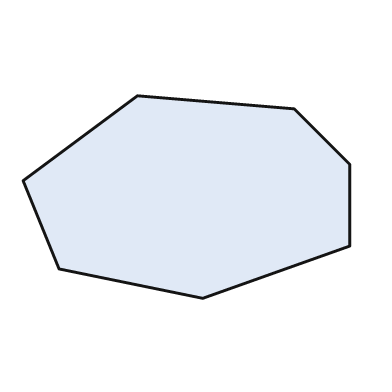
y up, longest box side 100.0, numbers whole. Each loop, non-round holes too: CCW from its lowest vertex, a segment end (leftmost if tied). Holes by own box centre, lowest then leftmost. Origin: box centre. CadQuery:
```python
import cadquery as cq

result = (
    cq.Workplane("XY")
    .moveTo(5.0, -31.0)
    .lineTo(50.0, -15.0)
    .lineTo(50.0, 10.0)
    .lineTo(33.0, 27.0)
    .lineTo(-15.0, 31.0)
    .lineTo(-50.0, 5.0)
    .lineTo(-39.0, -22.0)
    .close()
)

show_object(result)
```